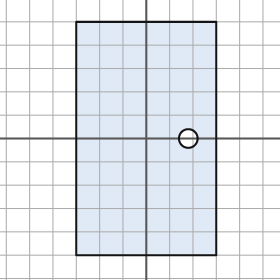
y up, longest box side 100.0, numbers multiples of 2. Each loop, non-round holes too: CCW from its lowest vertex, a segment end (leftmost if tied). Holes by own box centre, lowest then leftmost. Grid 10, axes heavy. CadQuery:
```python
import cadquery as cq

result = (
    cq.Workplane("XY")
    .moveTo(-30.0, -50.0)
    .lineTo(30.0, -50.0)
    .lineTo(30.0, 50.0)
    .lineTo(-30.0, 50.0)
    .close()
    .moveTo(18.0, 0.0)
    .circle(4.0)
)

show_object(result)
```